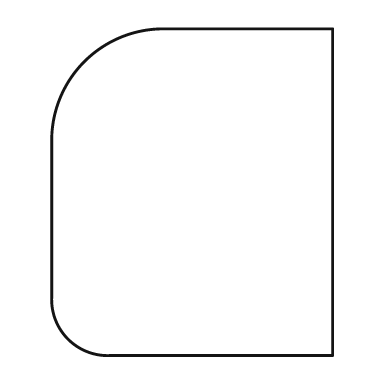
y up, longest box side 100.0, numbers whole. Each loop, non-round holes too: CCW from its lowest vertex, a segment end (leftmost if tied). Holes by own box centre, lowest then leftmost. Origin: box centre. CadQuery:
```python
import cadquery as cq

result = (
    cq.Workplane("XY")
    .moveTo(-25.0, -50.0)
    .lineTo(43.0, -50.0)
    .lineTo(43.0, 50.0)
    .lineTo(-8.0, 50.0)
    .threePointArc((-33.0, 40.0), (-43.0, 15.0))
    .lineTo(-43.0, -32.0)
    .threePointArc((-38.0, -45.0), (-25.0, -50.0))
    .close()
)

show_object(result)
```